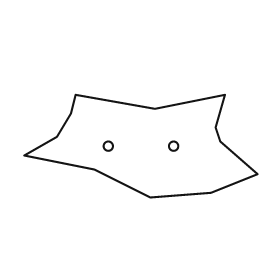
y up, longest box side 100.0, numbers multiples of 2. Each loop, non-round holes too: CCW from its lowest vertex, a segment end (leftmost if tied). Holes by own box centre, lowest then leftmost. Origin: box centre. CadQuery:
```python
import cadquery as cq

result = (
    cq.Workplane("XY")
    .moveTo(4.0, -22.0)
    .lineTo(30.0, -20.0)
    .lineTo(50.0, -12.0)
    .lineTo(34.0, 2.0)
    .lineTo(32.0, 8.0)
    .lineTo(36.0, 22.0)
    .lineTo(6.0, 16.0)
    .lineTo(-28.0, 22.0)
    .lineTo(-30.0, 14.0)
    .lineTo(-36.0, 4.0)
    .lineTo(-50.0, -4.0)
    .lineTo(-20.0, -10.0)
    .close()
    .moveTo(-14.0, 0.0)
    .circle(2.0)
    .moveTo(14.0, 0.0)
    .circle(2.0)
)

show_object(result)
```